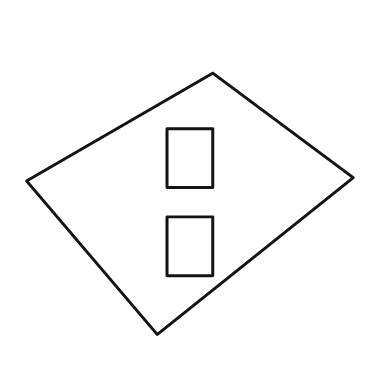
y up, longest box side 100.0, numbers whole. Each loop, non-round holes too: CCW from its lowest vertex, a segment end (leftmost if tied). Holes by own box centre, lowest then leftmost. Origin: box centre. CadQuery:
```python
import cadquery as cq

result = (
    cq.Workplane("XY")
    .moveTo(-10.0, -40.0)
    .lineTo(50.0, 8.0)
    .lineTo(7.0, 40.0)
    .lineTo(-50.0, 7.0)
    .close()
    .moveTo(-7.0, -22.0)
    .lineTo(7.0, -22.0)
    .lineTo(7.0, -4.0)
    .lineTo(-7.0, -4.0)
    .close()
    .moveTo(-7.0, 5.0)
    .lineTo(7.0, 5.0)
    .lineTo(7.0, 23.0)
    .lineTo(-7.0, 23.0)
    .close()
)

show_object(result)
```